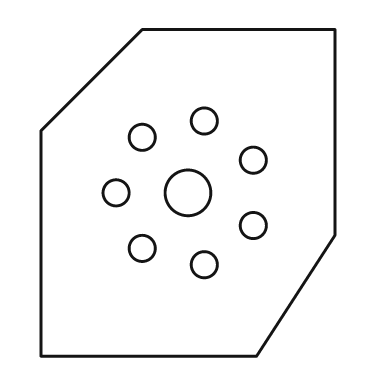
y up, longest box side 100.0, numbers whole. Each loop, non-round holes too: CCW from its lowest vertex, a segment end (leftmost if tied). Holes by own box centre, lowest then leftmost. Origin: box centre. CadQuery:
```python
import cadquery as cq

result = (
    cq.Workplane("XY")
    .moveTo(-45.0, -50.0)
    .lineTo(21.0, -50.0)
    .lineTo(45.0, -13.0)
    .lineTo(45.0, 50.0)
    .lineTo(-14.0, 50.0)
    .lineTo(-45.0, 19.0)
    .close()
    .moveTo(5.0, -22.0)
    .circle(4.0)
    .moveTo(-14.0, -17.0)
    .circle(4.0)
    .moveTo(20.0, -10.0)
    .circle(4.0)
    .moveTo(-22.0, 0.0)
    .circle(4.0)
    .moveTo(0.0, 0.0)
    .circle(7.0)
    .moveTo(20.0, 10.0)
    .circle(4.0)
    .moveTo(-14.0, 17.0)
    .circle(4.0)
    .moveTo(5.0, 22.0)
    .circle(4.0)
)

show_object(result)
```